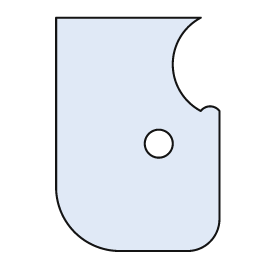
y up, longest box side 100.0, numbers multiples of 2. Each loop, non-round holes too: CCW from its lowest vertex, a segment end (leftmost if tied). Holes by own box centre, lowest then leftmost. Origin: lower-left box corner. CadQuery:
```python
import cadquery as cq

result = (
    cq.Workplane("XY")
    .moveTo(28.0, 0.0)
    .lineTo(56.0, 0.0)
    .threePointArc((66.0, 4.0), (70.0, 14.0))
    .lineTo(70.0, 60.0)
    .threePointArc((66.0, 62.0), (62.0, 60.0))
    .threePointArc((50.0, 80.0), (62.0, 100.0))
    .lineTo(0.0, 100.0)
    .lineTo(0.0, 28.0)
    .threePointArc((8.0, 8.0), (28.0, 0.0))
    .close()
    .moveTo(44.0, 46.0)
    .circle(6.0)
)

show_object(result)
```